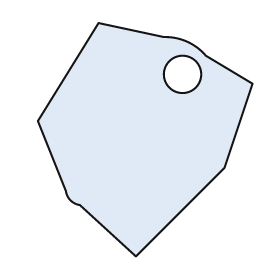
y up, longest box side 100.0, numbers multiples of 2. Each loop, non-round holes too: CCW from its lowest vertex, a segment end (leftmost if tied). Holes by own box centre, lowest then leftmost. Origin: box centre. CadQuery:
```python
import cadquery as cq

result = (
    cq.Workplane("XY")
    .moveTo(-4.0, -50.0)
    .lineTo(34.0, -12.0)
    .lineTo(46.0, 24.0)
    .lineTo(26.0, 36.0)
    .threePointArc((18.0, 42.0), (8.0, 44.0))
    .lineTo(-20.0, 50.0)
    .lineTo(-46.0, 8.0)
    .lineTo(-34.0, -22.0)
    .threePointArc((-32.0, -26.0), (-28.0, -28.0))
    .close()
    .moveTo(16.0, 28.0)
    .circle(8.0)
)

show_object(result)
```